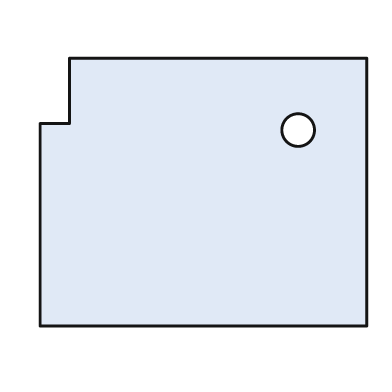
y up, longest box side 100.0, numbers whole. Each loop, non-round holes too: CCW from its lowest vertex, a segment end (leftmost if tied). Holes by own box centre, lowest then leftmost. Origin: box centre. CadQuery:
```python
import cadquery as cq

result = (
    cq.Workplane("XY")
    .moveTo(-50.0, -41.0)
    .lineTo(50.0, -41.0)
    .lineTo(50.0, 41.0)
    .lineTo(-41.0, 41.0)
    .lineTo(-41.0, 21.0)
    .lineTo(-50.0, 21.0)
    .close()
    .moveTo(29.0, 19.0)
    .circle(5.0)
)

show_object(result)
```